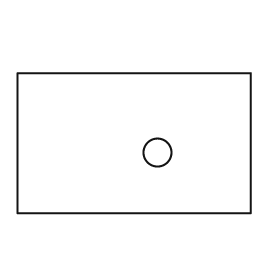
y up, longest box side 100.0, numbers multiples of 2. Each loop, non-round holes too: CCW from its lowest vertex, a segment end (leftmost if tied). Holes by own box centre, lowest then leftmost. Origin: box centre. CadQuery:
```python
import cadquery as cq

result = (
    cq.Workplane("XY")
    .moveTo(-50.0, -30.0)
    .lineTo(50.0, -30.0)
    .lineTo(50.0, 30.0)
    .lineTo(-50.0, 30.0)
    .close()
    .moveTo(10.0, -4.0)
    .circle(6.0)
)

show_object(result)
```